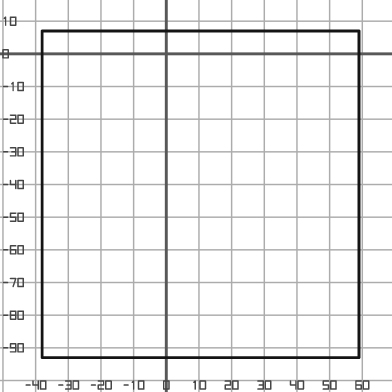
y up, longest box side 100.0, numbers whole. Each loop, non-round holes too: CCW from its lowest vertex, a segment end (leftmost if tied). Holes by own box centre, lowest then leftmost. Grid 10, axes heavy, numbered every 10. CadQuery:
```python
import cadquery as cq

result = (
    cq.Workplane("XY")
    .moveTo(-38.0, -93.0)
    .lineTo(59.0, -93.0)
    .lineTo(59.0, 7.0)
    .lineTo(-38.0, 7.0)
    .close()
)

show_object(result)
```